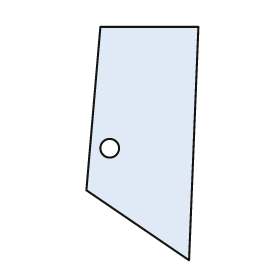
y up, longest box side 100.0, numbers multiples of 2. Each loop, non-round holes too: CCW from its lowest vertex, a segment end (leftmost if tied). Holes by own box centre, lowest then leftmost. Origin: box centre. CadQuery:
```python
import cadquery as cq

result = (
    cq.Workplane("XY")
    .moveTo(20.0, -50.0)
    .lineTo(24.0, 50.0)
    .lineTo(-18.0, 50.0)
    .lineTo(-24.0, -20.0)
    .close()
    .moveTo(-14.0, -2.0)
    .circle(4.0)
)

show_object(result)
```